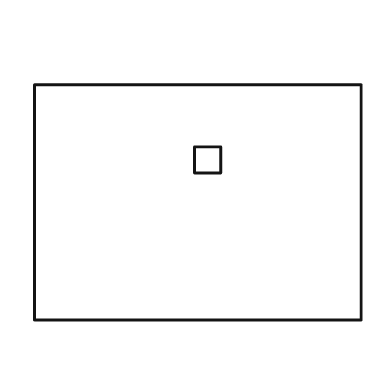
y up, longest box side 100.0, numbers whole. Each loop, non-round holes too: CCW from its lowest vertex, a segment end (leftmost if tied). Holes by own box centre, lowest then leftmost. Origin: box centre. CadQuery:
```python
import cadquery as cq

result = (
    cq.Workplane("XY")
    .moveTo(-50.0, -36.0)
    .lineTo(50.0, -36.0)
    .lineTo(50.0, 36.0)
    .lineTo(-50.0, 36.0)
    .close()
    .moveTo(-1.0, 9.0)
    .lineTo(7.0, 9.0)
    .lineTo(7.0, 17.0)
    .lineTo(-1.0, 17.0)
    .close()
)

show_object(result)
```